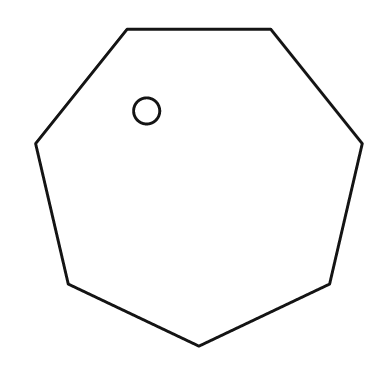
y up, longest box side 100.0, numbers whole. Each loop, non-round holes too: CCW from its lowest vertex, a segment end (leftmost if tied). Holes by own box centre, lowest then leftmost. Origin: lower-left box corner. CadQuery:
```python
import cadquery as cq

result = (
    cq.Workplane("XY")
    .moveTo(50.0, 0.0)
    .lineTo(90.0, 19.0)
    .lineTo(100.0, 62.0)
    .lineTo(72.0, 97.0)
    .lineTo(28.0, 97.0)
    .lineTo(0.0, 62.0)
    .lineTo(10.0, 19.0)
    .close()
    .moveTo(34.0, 72.0)
    .circle(4.0)
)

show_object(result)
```